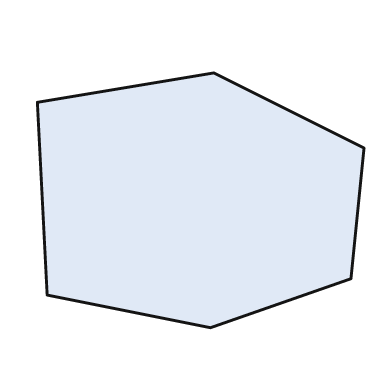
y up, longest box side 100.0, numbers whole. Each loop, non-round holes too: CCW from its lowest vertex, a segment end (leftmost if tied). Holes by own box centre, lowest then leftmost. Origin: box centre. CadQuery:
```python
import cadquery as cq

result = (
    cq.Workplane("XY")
    .moveTo(3.0, -39.0)
    .lineTo(46.0, -24.0)
    .lineTo(50.0, 16.0)
    .lineTo(4.0, 39.0)
    .lineTo(-50.0, 30.0)
    .lineTo(-47.0, -29.0)
    .close()
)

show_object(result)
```